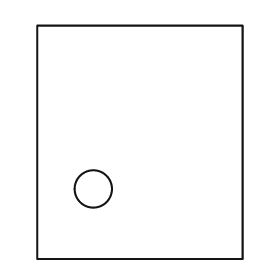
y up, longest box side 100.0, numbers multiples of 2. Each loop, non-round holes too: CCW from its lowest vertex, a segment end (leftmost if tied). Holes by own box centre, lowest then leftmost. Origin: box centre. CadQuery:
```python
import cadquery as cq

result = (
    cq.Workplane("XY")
    .moveTo(-44.0, -50.0)
    .lineTo(44.0, -50.0)
    .lineTo(44.0, 50.0)
    .lineTo(-44.0, 50.0)
    .close()
    .moveTo(-20.0, -20.0)
    .circle(8.0)
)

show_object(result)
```